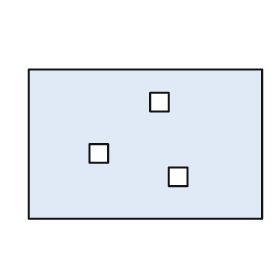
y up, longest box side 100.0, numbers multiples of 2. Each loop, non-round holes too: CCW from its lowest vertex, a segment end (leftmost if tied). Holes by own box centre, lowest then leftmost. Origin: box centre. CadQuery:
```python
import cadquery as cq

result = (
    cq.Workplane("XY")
    .moveTo(-50.0, -32.0)
    .lineTo(50.0, -32.0)
    .lineTo(50.0, 32.0)
    .lineTo(-50.0, 32.0)
    .close()
    .moveTo(10.0, -18.0)
    .lineTo(18.0, -18.0)
    .lineTo(18.0, -10.0)
    .lineTo(10.0, -10.0)
    .close()
    .moveTo(-24.0, -8.0)
    .lineTo(-16.0, -8.0)
    .lineTo(-16.0, 0.0)
    .lineTo(-24.0, 0.0)
    .close()
    .moveTo(2.0, 14.0)
    .lineTo(10.0, 14.0)
    .lineTo(10.0, 22.0)
    .lineTo(2.0, 22.0)
    .close()
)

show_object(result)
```